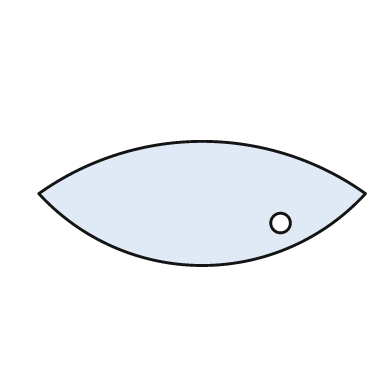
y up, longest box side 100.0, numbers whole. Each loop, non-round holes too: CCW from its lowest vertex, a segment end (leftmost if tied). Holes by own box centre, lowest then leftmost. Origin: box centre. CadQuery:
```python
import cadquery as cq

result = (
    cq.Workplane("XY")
    .moveTo(-50.0, 3.0)
    .threePointArc((0.0, -19.0), (50.0, 3.0))
    .threePointArc((0.0, 19.0), (-50.0, 3.0))
    .close()
    .moveTo(24.0, -6.0)
    .circle(3.0)
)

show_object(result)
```